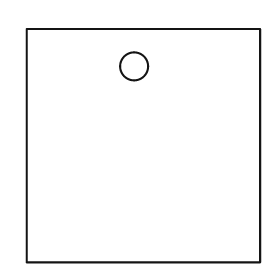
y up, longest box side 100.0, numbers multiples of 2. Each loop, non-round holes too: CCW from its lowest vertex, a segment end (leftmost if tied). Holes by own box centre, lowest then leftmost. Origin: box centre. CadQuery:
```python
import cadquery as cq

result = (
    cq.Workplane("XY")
    .moveTo(-50.0, -50.0)
    .lineTo(50.0, -50.0)
    .lineTo(50.0, 50.0)
    .lineTo(-50.0, 50.0)
    .close()
    .moveTo(-4.0, 34.0)
    .circle(6.0)
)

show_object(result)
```